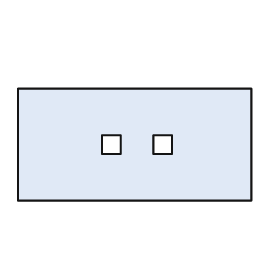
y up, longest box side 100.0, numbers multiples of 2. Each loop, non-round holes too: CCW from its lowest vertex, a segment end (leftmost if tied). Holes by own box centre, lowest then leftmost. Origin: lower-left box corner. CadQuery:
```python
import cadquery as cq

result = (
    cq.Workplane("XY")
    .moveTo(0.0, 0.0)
    .lineTo(100.0, 0.0)
    .lineTo(100.0, 48.0)
    .lineTo(0.0, 48.0)
    .close()
    .moveTo(36.0, 20.0)
    .lineTo(44.0, 20.0)
    .lineTo(44.0, 28.0)
    .lineTo(36.0, 28.0)
    .close()
    .moveTo(58.0, 20.0)
    .lineTo(66.0, 20.0)
    .lineTo(66.0, 28.0)
    .lineTo(58.0, 28.0)
    .close()
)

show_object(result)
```